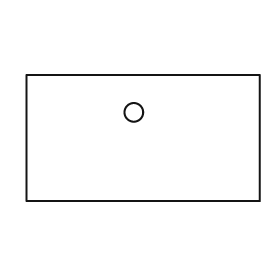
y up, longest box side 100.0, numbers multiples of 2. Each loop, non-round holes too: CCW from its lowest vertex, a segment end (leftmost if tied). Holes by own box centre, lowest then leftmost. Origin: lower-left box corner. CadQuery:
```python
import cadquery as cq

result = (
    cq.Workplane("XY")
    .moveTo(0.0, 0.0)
    .lineTo(100.0, 0.0)
    .lineTo(100.0, 54.0)
    .lineTo(0.0, 54.0)
    .close()
    .moveTo(46.0, 38.0)
    .circle(4.0)
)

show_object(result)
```